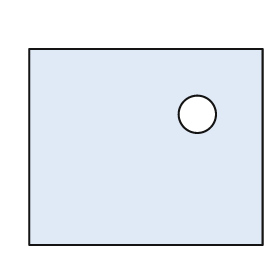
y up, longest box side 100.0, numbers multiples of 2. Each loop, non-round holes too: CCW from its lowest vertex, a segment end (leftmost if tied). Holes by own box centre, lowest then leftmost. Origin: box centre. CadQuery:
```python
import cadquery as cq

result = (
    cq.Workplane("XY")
    .moveTo(-50.0, -42.0)
    .lineTo(50.0, -42.0)
    .lineTo(50.0, 42.0)
    .lineTo(-50.0, 42.0)
    .close()
    .moveTo(22.0, 14.0)
    .circle(8.0)
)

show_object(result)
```